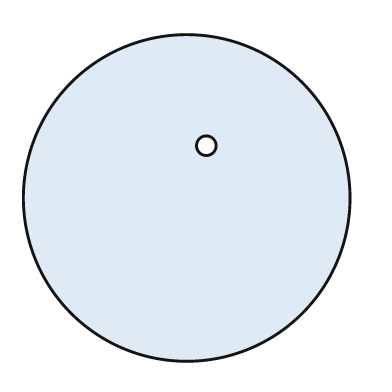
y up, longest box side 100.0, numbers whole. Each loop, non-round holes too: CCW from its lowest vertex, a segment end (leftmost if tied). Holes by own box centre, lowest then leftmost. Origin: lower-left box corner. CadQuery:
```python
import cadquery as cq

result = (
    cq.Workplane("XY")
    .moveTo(50.0, 50.0)
    .circle(50.0)
    .moveTo(56.0, 66.0)
    .circle(3.0)
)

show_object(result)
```